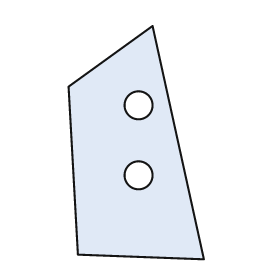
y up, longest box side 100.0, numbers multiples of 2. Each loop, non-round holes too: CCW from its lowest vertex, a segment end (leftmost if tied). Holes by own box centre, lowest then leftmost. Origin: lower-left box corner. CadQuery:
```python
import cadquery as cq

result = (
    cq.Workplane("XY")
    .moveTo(58.0, 0.0)
    .lineTo(36.0, 100.0)
    .lineTo(0.0, 74.0)
    .lineTo(4.0, 2.0)
    .close()
    .moveTo(30.0, 36.0)
    .circle(6.0)
    .moveTo(30.0, 66.0)
    .circle(6.0)
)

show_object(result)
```